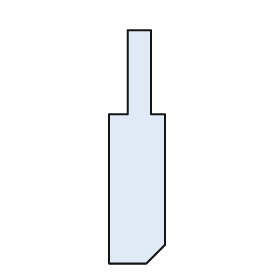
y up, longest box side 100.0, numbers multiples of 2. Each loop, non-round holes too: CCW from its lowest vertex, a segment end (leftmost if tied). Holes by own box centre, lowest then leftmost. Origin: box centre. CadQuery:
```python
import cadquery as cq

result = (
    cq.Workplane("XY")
    .moveTo(-12.0, -50.0)
    .lineTo(4.0, -50.0)
    .lineTo(12.0, -42.0)
    .lineTo(12.0, 14.0)
    .lineTo(6.0, 14.0)
    .lineTo(6.0, 50.0)
    .lineTo(-4.0, 50.0)
    .lineTo(-4.0, 14.0)
    .lineTo(-12.0, 14.0)
    .close()
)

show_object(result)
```